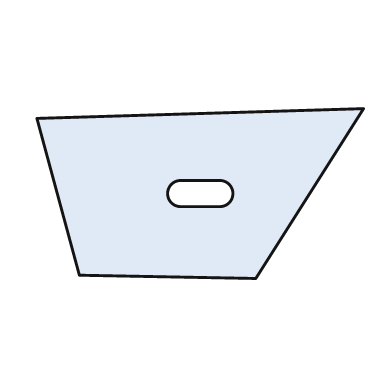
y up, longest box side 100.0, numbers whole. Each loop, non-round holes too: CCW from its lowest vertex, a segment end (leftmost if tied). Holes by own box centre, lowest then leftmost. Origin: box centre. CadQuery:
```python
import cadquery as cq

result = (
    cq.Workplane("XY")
    .moveTo(17.0, -26.0)
    .lineTo(50.0, 26.0)
    .lineTo(-50.0, 23.0)
    .lineTo(-37.0, -25.0)
    .close()
    .moveTo(-6.0, -4.0)
    .lineTo(6.0, -4.0)
    .threePointArc((10.0, 0.0), (6.0, 4.0))
    .lineTo(-6.0, 4.0)
    .threePointArc((-10.0, 0.0), (-6.0, -4.0))
    .close()
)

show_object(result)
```